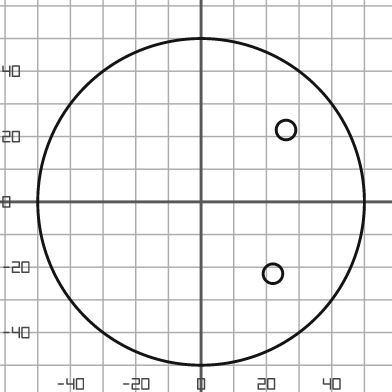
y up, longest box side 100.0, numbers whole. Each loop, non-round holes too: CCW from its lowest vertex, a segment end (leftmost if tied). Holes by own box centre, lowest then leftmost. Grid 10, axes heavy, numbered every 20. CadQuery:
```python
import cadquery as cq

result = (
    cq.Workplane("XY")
    .moveTo(0.0, 0.0)
    .circle(50.0)
    .moveTo(22.0, -22.0)
    .circle(3.0)
    .moveTo(26.0, 22.0)
    .circle(3.0)
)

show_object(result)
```